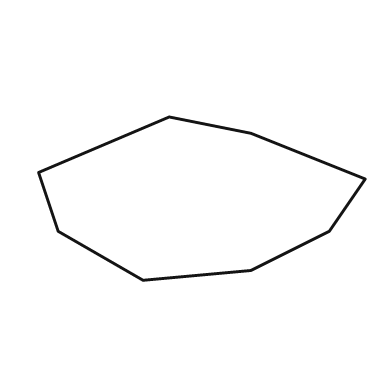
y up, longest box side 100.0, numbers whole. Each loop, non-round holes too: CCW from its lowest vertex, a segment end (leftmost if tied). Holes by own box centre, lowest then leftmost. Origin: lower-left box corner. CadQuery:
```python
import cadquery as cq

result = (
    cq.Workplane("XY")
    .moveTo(32.0, 0.0)
    .lineTo(65.0, 3.0)
    .lineTo(89.0, 15.0)
    .lineTo(100.0, 31.0)
    .lineTo(65.0, 45.0)
    .lineTo(40.0, 50.0)
    .lineTo(0.0, 33.0)
    .lineTo(6.0, 15.0)
    .close()
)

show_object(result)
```